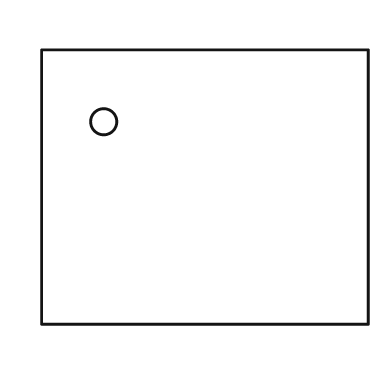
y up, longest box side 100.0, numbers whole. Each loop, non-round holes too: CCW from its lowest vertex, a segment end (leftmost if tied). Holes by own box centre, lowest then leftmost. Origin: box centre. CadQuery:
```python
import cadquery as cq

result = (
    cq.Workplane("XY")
    .moveTo(-50.0, -42.0)
    .lineTo(50.0, -42.0)
    .lineTo(50.0, 42.0)
    .lineTo(-50.0, 42.0)
    .close()
    .moveTo(-31.0, 20.0)
    .circle(4.0)
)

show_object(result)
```